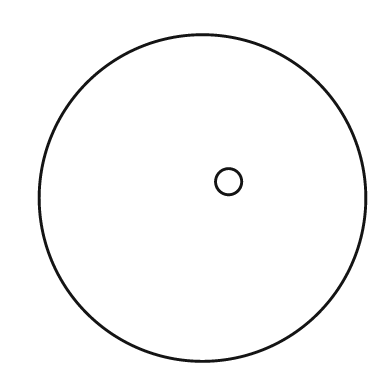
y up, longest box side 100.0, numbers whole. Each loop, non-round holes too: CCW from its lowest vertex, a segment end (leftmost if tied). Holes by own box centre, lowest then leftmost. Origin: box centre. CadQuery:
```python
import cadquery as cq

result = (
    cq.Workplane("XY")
    .moveTo(0.0, 0.0)
    .circle(50.0)
    .moveTo(8.0, 5.0)
    .circle(4.0)
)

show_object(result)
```